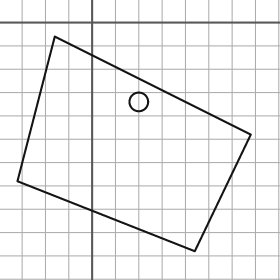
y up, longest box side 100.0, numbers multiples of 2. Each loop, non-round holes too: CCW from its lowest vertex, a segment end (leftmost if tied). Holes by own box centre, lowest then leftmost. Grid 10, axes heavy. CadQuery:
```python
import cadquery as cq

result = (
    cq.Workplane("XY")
    .moveTo(44.0, -98.0)
    .lineTo(68.0, -48.0)
    .lineTo(-16.0, -6.0)
    .lineTo(-32.0, -68.0)
    .close()
    .moveTo(20.0, -34.0)
    .circle(4.0)
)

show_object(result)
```